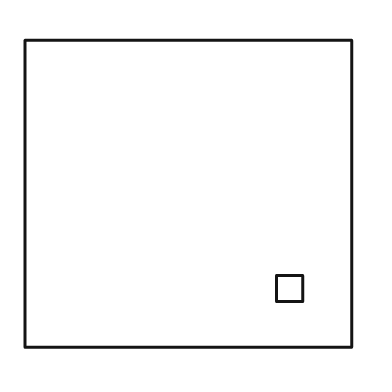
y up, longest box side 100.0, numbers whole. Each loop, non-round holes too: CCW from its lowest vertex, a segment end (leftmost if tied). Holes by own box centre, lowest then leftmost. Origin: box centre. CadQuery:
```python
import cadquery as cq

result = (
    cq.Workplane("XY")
    .moveTo(-50.0, -47.0)
    .lineTo(50.0, -47.0)
    .lineTo(50.0, 47.0)
    .lineTo(-50.0, 47.0)
    .close()
    .moveTo(27.0, -33.0)
    .lineTo(35.0, -33.0)
    .lineTo(35.0, -25.0)
    .lineTo(27.0, -25.0)
    .close()
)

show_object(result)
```